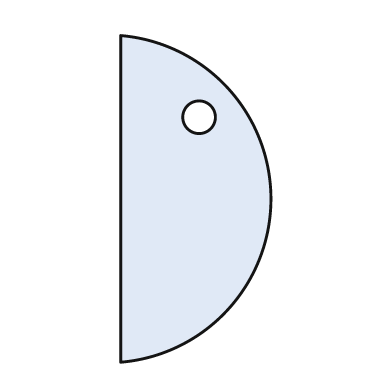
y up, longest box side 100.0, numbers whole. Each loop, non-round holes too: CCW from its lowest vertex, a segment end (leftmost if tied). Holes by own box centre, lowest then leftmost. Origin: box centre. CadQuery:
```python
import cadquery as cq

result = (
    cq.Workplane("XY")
    .moveTo(-23.0, -50.0)
    .threePointArc((23.0, 0.0), (-23.0, 50.0))
    .close()
    .moveTo(1.0, 25.0)
    .circle(5.0)
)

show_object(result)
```